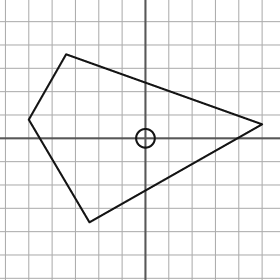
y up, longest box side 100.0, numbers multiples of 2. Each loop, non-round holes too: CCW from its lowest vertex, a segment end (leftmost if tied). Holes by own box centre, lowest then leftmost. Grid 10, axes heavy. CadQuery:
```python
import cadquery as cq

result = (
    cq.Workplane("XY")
    .moveTo(-24.0, -36.0)
    .lineTo(50.0, 6.0)
    .lineTo(-34.0, 36.0)
    .lineTo(-50.0, 8.0)
    .close()
    .moveTo(0.0, 0.0)
    .circle(4.0)
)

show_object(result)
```